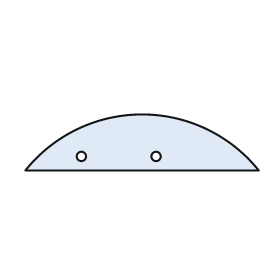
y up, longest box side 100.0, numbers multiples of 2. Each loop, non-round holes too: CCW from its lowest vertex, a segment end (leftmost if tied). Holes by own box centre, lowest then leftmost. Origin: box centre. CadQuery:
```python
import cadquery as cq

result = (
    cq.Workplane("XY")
    .moveTo(-50.0, -12.0)
    .lineTo(50.0, -12.0)
    .threePointArc((0.0, 12.0), (-50.0, -12.0))
    .close()
    .moveTo(-26.0, -6.0)
    .circle(2.0)
    .moveTo(6.0, -6.0)
    .circle(2.0)
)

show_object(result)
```